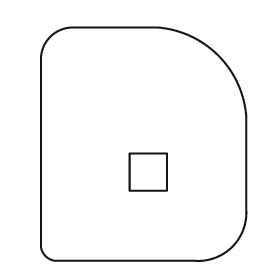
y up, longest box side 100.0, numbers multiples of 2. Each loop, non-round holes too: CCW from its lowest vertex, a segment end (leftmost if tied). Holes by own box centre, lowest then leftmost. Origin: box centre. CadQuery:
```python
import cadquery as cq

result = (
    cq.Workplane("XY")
    .moveTo(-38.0, -50.0)
    .lineTo(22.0, -50.0)
    .threePointArc((38.0, -44.0), (44.0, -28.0))
    .lineTo(44.0, 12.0)
    .threePointArc((32.0, 38.0), (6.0, 50.0))
    .lineTo(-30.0, 50.0)
    .threePointArc((-40.0, 46.0), (-44.0, 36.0))
    .lineTo(-44.0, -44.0)
    .threePointArc((-42.0, -48.0), (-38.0, -50.0))
    .close()
    .moveTo(-6.0, -20.0)
    .lineTo(10.0, -20.0)
    .lineTo(10.0, -4.0)
    .lineTo(-6.0, -4.0)
    .close()
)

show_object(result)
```